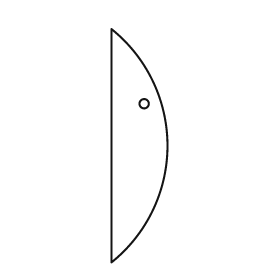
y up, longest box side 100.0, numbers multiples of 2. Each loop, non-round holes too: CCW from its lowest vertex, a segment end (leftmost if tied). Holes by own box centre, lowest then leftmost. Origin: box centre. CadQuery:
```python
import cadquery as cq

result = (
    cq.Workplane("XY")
    .moveTo(-12.0, -50.0)
    .threePointArc((12.0, 0.0), (-12.0, 50.0))
    .close()
    .moveTo(2.0, 18.0)
    .circle(2.0)
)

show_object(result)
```